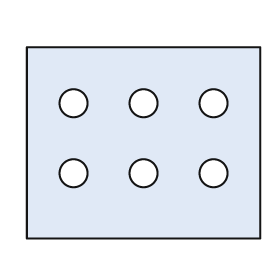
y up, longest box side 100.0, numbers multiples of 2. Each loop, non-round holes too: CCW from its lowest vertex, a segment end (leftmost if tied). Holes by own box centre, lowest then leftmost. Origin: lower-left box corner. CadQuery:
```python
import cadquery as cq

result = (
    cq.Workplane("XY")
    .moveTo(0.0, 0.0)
    .lineTo(100.0, 0.0)
    .lineTo(100.0, 82.0)
    .lineTo(0.0, 82.0)
    .close()
    .moveTo(20.0, 28.0)
    .circle(6.0)
    .moveTo(50.0, 28.0)
    .circle(6.0)
    .moveTo(80.0, 28.0)
    .circle(6.0)
    .moveTo(20.0, 58.0)
    .circle(6.0)
    .moveTo(50.0, 58.0)
    .circle(6.0)
    .moveTo(80.0, 58.0)
    .circle(6.0)
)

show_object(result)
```